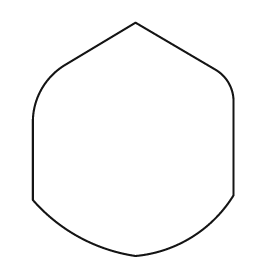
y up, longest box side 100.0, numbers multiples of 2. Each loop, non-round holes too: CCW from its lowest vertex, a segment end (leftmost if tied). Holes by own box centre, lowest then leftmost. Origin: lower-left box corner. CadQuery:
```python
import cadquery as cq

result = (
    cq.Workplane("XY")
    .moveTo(44.0, 0.0)
    .threePointArc((68.0, 8.0), (86.0, 26.0))
    .lineTo(86.0, 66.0)
    .threePointArc((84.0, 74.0), (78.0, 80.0))
    .lineTo(44.0, 100.0)
    .lineTo(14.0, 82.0)
    .threePointArc((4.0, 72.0), (0.0, 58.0))
    .lineTo(0.0, 24.0)
    .threePointArc((20.0, 8.0), (44.0, 0.0))
    .close()
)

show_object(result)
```